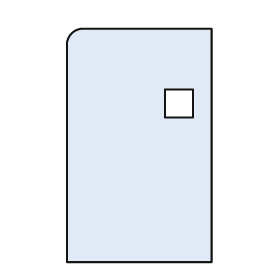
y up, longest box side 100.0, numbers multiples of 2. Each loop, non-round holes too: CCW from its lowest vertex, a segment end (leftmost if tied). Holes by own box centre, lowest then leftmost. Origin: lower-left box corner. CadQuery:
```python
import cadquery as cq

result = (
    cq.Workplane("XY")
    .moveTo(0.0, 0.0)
    .lineTo(62.0, 0.0)
    .lineTo(62.0, 100.0)
    .lineTo(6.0, 100.0)
    .threePointArc((2.0, 98.0), (0.0, 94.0))
    .close()
    .moveTo(42.0, 62.0)
    .lineTo(54.0, 62.0)
    .lineTo(54.0, 74.0)
    .lineTo(42.0, 74.0)
    .close()
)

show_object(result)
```